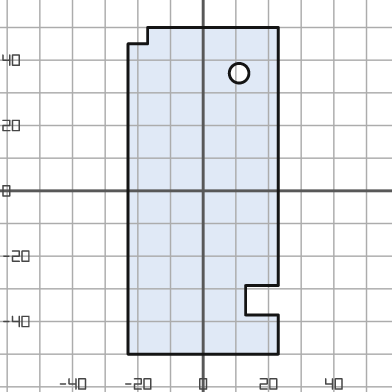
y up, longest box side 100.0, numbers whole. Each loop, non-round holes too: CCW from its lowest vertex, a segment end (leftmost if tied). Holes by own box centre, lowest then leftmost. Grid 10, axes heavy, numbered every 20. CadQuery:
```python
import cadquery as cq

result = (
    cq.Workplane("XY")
    .moveTo(-23.0, -50.0)
    .lineTo(23.0, -50.0)
    .lineTo(23.0, -38.0)
    .lineTo(13.0, -38.0)
    .lineTo(13.0, -29.0)
    .lineTo(23.0, -29.0)
    .lineTo(23.0, 50.0)
    .lineTo(-17.0, 50.0)
    .lineTo(-17.0, 45.0)
    .lineTo(-23.0, 45.0)
    .close()
    .moveTo(11.0, 36.0)
    .circle(3.0)
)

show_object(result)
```